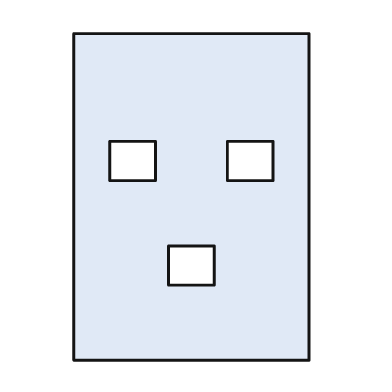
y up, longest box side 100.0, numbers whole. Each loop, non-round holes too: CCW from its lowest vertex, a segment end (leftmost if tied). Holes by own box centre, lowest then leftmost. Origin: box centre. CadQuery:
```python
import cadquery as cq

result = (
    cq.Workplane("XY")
    .moveTo(-36.0, -50.0)
    .lineTo(36.0, -50.0)
    .lineTo(36.0, 50.0)
    .lineTo(-36.0, 50.0)
    .close()
    .moveTo(-7.0, -27.0)
    .lineTo(7.0, -27.0)
    .lineTo(7.0, -15.0)
    .lineTo(-7.0, -15.0)
    .close()
    .moveTo(-25.0, 5.0)
    .lineTo(-11.0, 5.0)
    .lineTo(-11.0, 17.0)
    .lineTo(-25.0, 17.0)
    .close()
    .moveTo(11.0, 5.0)
    .lineTo(25.0, 5.0)
    .lineTo(25.0, 17.0)
    .lineTo(11.0, 17.0)
    .close()
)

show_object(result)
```